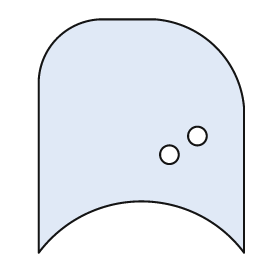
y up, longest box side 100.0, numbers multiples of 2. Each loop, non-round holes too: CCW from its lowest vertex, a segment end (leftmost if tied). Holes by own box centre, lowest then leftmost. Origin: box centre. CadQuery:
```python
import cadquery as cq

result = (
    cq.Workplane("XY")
    .moveTo(-44.0, -50.0)
    .threePointArc((0.0, -28.0), (44.0, -50.0))
    .lineTo(44.0, 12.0)
    .threePointArc((32.0, 38.0), (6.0, 50.0))
    .lineTo(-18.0, 50.0)
    .threePointArc((-36.0, 42.0), (-44.0, 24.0))
    .close()
    .moveTo(12.0, -8.0)
    .circle(4.0)
    .moveTo(24.0, 0.0)
    .circle(4.0)
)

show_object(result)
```